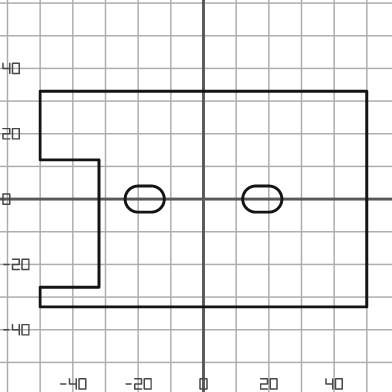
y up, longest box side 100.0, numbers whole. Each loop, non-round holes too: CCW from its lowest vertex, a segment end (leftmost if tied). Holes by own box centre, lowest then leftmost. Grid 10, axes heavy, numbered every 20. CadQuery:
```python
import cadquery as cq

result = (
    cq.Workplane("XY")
    .moveTo(-50.0, -33.0)
    .lineTo(50.0, -33.0)
    .lineTo(50.0, 33.0)
    .lineTo(-50.0, 33.0)
    .lineTo(-50.0, 12.0)
    .lineTo(-32.0, 12.0)
    .lineTo(-32.0, -27.0)
    .lineTo(-50.0, -27.0)
    .close()
    .moveTo(-20.0, -4.0)
    .lineTo(-16.0, -4.0)
    .threePointArc((-12.0, 0.0), (-16.0, 4.0))
    .lineTo(-20.0, 4.0)
    .threePointArc((-24.0, 0.0), (-20.0, -4.0))
    .close()
    .moveTo(16.0, -4.0)
    .lineTo(20.0, -4.0)
    .threePointArc((24.0, 0.0), (20.0, 4.0))
    .lineTo(16.0, 4.0)
    .threePointArc((12.0, 0.0), (16.0, -4.0))
    .close()
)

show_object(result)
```